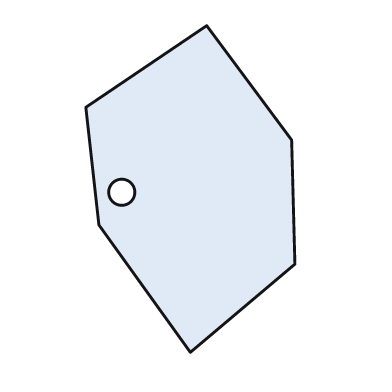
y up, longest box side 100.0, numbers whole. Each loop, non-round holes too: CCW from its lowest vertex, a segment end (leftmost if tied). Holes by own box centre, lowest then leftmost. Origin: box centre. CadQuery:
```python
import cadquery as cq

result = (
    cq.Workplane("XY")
    .moveTo(0.0, -50.0)
    .lineTo(32.0, -23.0)
    .lineTo(31.0, 15.0)
    .lineTo(5.0, 50.0)
    .lineTo(-32.0, 25.0)
    .lineTo(-28.0, -11.0)
    .close()
    .moveTo(-21.0, -1.0)
    .circle(4.0)
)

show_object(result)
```